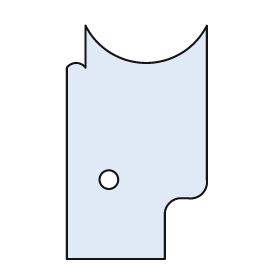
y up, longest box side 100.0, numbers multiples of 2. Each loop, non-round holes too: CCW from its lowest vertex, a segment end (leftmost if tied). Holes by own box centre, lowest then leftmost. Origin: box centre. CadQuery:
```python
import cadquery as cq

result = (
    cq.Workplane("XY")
    .moveTo(-30.0, -50.0)
    .lineTo(12.0, -50.0)
    .lineTo(12.0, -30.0)
    .threePointArc((14.0, -26.0), (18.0, -24.0))
    .lineTo(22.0, -24.0)
    .threePointArc((28.0, -22.0), (30.0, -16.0))
    .lineTo(30.0, 50.0)
    .threePointArc((4.0, 34.0), (-22.0, 50.0))
    .lineTo(-22.0, 32.0)
    .threePointArc((-26.0, 34.0), (-30.0, 32.0))
    .close()
    .moveTo(-12.0, -16.0)
    .circle(4.0)
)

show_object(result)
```